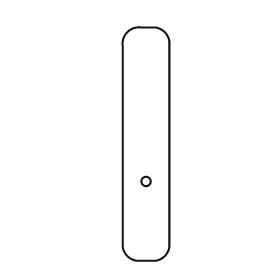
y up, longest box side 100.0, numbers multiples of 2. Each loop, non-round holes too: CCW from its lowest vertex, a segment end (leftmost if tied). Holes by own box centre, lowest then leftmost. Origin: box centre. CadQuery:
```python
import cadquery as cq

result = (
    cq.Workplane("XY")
    .moveTo(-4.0, -50.0)
    .lineTo(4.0, -50.0)
    .threePointArc((8.0, -48.0), (10.0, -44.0))
    .lineTo(10.0, 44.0)
    .threePointArc((8.0, 48.0), (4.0, 50.0))
    .lineTo(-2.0, 50.0)
    .threePointArc((-8.0, 48.0), (-10.0, 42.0))
    .lineTo(-10.0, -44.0)
    .threePointArc((-8.0, -48.0), (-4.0, -50.0))
    .close()
    .moveTo(0.0, -16.0)
    .circle(2.0)
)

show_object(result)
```